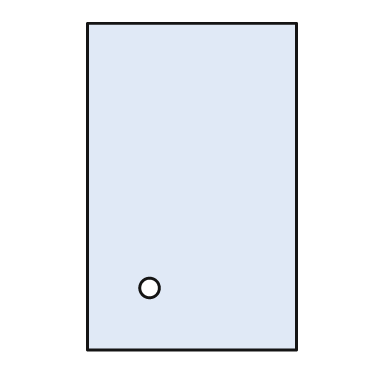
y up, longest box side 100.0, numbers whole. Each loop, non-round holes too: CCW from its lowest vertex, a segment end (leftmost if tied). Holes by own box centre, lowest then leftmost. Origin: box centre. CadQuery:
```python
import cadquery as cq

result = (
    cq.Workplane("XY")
    .moveTo(-32.0, -50.0)
    .lineTo(32.0, -50.0)
    .lineTo(32.0, 50.0)
    .lineTo(-32.0, 50.0)
    .close()
    .moveTo(-13.0, -31.0)
    .circle(3.0)
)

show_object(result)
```